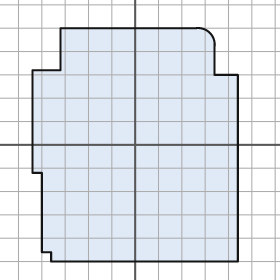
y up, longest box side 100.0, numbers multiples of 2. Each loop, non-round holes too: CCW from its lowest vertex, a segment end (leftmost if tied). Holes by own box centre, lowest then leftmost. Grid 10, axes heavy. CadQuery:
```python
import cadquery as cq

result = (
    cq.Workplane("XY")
    .moveTo(-36.0, -50.0)
    .lineTo(44.0, -50.0)
    .lineTo(44.0, 30.0)
    .lineTo(34.0, 30.0)
    .lineTo(34.0, 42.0)
    .threePointArc((32.0, 48.0), (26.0, 50.0))
    .lineTo(-32.0, 50.0)
    .lineTo(-32.0, 32.0)
    .lineTo(-44.0, 32.0)
    .lineTo(-44.0, -12.0)
    .lineTo(-40.0, -12.0)
    .lineTo(-40.0, -46.0)
    .lineTo(-36.0, -46.0)
    .close()
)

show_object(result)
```